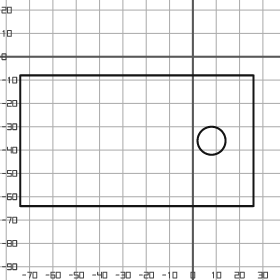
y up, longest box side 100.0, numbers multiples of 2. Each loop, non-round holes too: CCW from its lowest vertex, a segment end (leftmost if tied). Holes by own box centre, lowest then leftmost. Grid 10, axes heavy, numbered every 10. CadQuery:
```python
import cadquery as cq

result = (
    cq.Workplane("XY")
    .moveTo(-74.0, -64.0)
    .lineTo(26.0, -64.0)
    .lineTo(26.0, -8.0)
    .lineTo(-74.0, -8.0)
    .close()
    .moveTo(8.0, -36.0)
    .circle(6.0)
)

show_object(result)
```